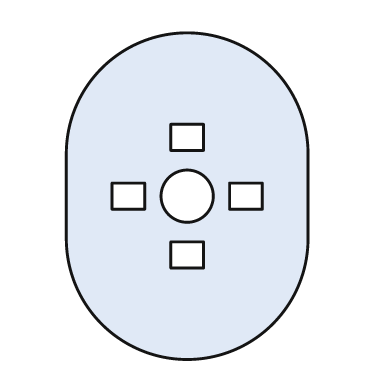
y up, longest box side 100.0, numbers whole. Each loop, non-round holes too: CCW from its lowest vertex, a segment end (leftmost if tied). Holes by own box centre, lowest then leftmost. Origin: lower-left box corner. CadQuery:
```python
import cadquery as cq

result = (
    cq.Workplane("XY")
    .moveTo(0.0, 37.0)
    .threePointArc((37.0, 0.0), (74.0, 37.0))
    .lineTo(74.0, 63.0)
    .threePointArc((37.0, 100.0), (0.0, 63.0))
    .close()
    .moveTo(32.0, 28.0)
    .lineTo(42.0, 28.0)
    .lineTo(42.0, 36.0)
    .lineTo(32.0, 36.0)
    .close()
    .moveTo(14.0, 46.0)
    .lineTo(24.0, 46.0)
    .lineTo(24.0, 54.0)
    .lineTo(14.0, 54.0)
    .close()
    .moveTo(37.0, 50.0)
    .circle(8.0)
    .moveTo(50.0, 46.0)
    .lineTo(60.0, 46.0)
    .lineTo(60.0, 54.0)
    .lineTo(50.0, 54.0)
    .close()
    .moveTo(32.0, 64.0)
    .lineTo(42.0, 64.0)
    .lineTo(42.0, 72.0)
    .lineTo(32.0, 72.0)
    .close()
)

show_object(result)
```